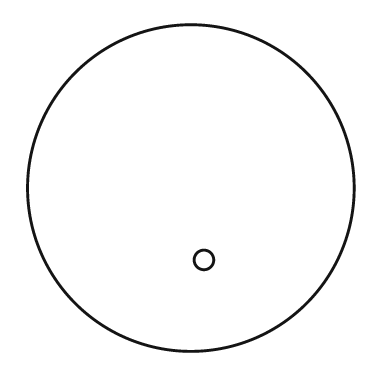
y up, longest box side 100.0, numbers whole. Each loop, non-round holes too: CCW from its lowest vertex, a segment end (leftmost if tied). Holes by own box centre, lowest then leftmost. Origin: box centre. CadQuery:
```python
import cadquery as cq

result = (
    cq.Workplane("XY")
    .moveTo(0.0, 0.0)
    .circle(50.0)
    .moveTo(4.0, -22.0)
    .circle(3.0)
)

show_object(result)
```